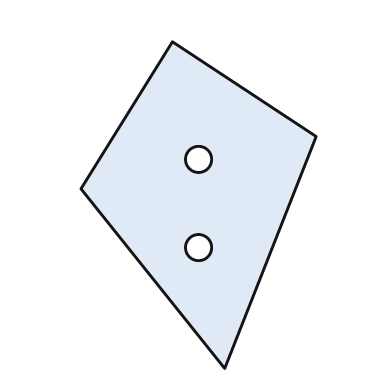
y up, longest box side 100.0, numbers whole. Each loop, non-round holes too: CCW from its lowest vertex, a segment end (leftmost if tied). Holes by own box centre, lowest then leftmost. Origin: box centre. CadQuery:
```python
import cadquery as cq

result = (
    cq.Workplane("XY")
    .moveTo(8.0, -50.0)
    .lineTo(36.0, 21.0)
    .lineTo(-8.0, 50.0)
    .lineTo(-36.0, 5.0)
    .close()
    .moveTo(0.0, -13.0)
    .circle(4.0)
    .moveTo(0.0, 14.0)
    .circle(4.0)
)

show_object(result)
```